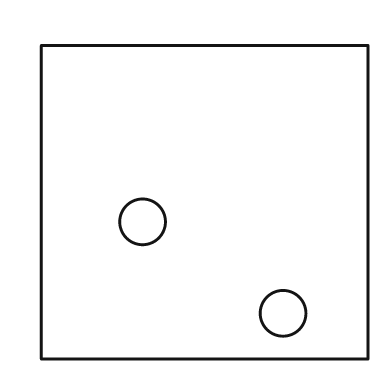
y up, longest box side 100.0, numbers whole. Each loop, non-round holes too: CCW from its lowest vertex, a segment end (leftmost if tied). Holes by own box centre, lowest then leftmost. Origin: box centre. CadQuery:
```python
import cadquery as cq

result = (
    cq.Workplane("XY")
    .moveTo(-50.0, -48.0)
    .lineTo(50.0, -48.0)
    .lineTo(50.0, 48.0)
    .lineTo(-50.0, 48.0)
    .close()
    .moveTo(24.0, -34.0)
    .circle(7.0)
    .moveTo(-19.0, -6.0)
    .circle(7.0)
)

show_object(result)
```